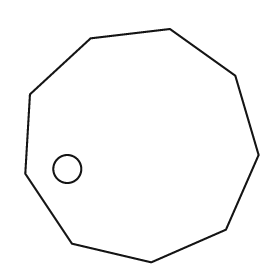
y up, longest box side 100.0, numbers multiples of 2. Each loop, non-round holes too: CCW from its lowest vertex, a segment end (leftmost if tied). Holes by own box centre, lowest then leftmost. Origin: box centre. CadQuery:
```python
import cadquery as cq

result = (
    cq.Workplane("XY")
    .moveTo(4.0, -50.0)
    .lineTo(36.0, -36.0)
    .lineTo(50.0, -4.0)
    .lineTo(40.0, 30.0)
    .lineTo(12.0, 50.0)
    .lineTo(-22.0, 46.0)
    .lineTo(-48.0, 22.0)
    .lineTo(-50.0, -12.0)
    .lineTo(-30.0, -42.0)
    .close()
    .moveTo(-32.0, -10.0)
    .circle(6.0)
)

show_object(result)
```